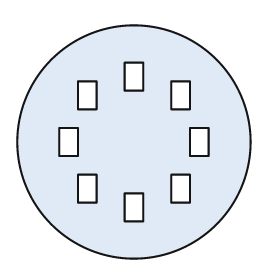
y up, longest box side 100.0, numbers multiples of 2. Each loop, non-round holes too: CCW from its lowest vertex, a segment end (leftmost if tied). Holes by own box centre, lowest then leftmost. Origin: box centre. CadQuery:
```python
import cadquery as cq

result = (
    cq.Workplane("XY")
    .moveTo(0.0, 0.0)
    .circle(50.0)
    .moveTo(-4.0, -34.0)
    .lineTo(4.0, -34.0)
    .lineTo(4.0, -22.0)
    .lineTo(-4.0, -22.0)
    .close()
    .moveTo(-24.0, -26.0)
    .lineTo(-16.0, -26.0)
    .lineTo(-16.0, -14.0)
    .lineTo(-24.0, -14.0)
    .close()
    .moveTo(16.0, -26.0)
    .lineTo(24.0, -26.0)
    .lineTo(24.0, -14.0)
    .lineTo(16.0, -14.0)
    .close()
    .moveTo(-32.0, -6.0)
    .lineTo(-24.0, -6.0)
    .lineTo(-24.0, 6.0)
    .lineTo(-32.0, 6.0)
    .close()
    .moveTo(24.0, -6.0)
    .lineTo(32.0, -6.0)
    .lineTo(32.0, 6.0)
    .lineTo(24.0, 6.0)
    .close()
    .moveTo(-24.0, 14.0)
    .lineTo(-16.0, 14.0)
    .lineTo(-16.0, 26.0)
    .lineTo(-24.0, 26.0)
    .close()
    .moveTo(16.0, 14.0)
    .lineTo(24.0, 14.0)
    .lineTo(24.0, 26.0)
    .lineTo(16.0, 26.0)
    .close()
    .moveTo(-4.0, 22.0)
    .lineTo(4.0, 22.0)
    .lineTo(4.0, 34.0)
    .lineTo(-4.0, 34.0)
    .close()
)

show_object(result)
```